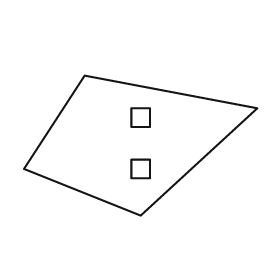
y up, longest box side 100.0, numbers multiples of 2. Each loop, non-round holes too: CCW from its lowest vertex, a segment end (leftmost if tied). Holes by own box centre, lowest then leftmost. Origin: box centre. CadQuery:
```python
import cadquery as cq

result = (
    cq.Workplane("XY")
    .moveTo(0.0, -30.0)
    .lineTo(50.0, 16.0)
    .lineTo(-24.0, 30.0)
    .lineTo(-50.0, -10.0)
    .close()
    .moveTo(-4.0, -14.0)
    .lineTo(4.0, -14.0)
    .lineTo(4.0, -6.0)
    .lineTo(-4.0, -6.0)
    .close()
    .moveTo(-4.0, 8.0)
    .lineTo(4.0, 8.0)
    .lineTo(4.0, 16.0)
    .lineTo(-4.0, 16.0)
    .close()
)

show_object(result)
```